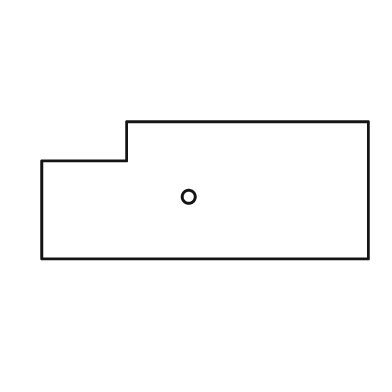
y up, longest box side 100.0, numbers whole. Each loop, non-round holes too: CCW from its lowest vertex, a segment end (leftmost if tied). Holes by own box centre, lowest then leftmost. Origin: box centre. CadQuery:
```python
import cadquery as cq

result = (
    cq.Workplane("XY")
    .moveTo(-50.0, -21.0)
    .lineTo(50.0, -21.0)
    .lineTo(50.0, 21.0)
    .lineTo(-24.0, 21.0)
    .lineTo(-24.0, 9.0)
    .lineTo(-50.0, 9.0)
    .close()
    .moveTo(-5.0, -2.0)
    .circle(2.0)
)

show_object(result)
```